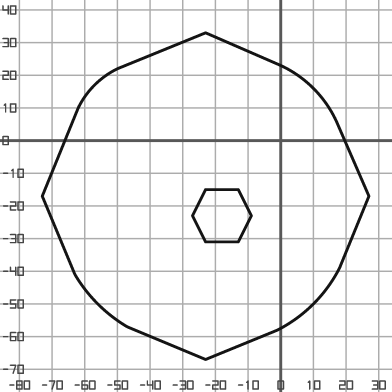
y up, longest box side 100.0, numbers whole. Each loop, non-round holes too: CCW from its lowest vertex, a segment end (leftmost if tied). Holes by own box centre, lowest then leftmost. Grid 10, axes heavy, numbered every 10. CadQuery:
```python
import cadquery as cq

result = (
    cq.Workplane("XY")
    .moveTo(-23.0, -67.0)
    .lineTo(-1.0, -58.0)
    .threePointArc((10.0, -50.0), (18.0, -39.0))
    .lineTo(27.0, -17.0)
    .lineTo(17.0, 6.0)
    .threePointArc((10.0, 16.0), (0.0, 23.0))
    .lineTo(-23.0, 33.0)
    .lineTo(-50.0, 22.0)
    .threePointArc((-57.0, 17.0), (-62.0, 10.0))
    .lineTo(-73.0, -17.0)
    .lineTo(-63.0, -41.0)
    .threePointArc((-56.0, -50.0), (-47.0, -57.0))
    .close()
    .moveTo(-23.0, -31.0)
    .lineTo(-13.0, -31.0)
    .lineTo(-9.0, -23.0)
    .lineTo(-13.0, -15.0)
    .lineTo(-23.0, -15.0)
    .lineTo(-27.0, -23.0)
    .close()
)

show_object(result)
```